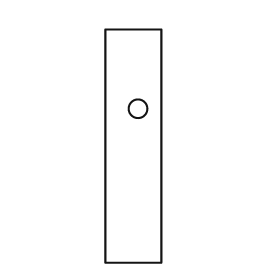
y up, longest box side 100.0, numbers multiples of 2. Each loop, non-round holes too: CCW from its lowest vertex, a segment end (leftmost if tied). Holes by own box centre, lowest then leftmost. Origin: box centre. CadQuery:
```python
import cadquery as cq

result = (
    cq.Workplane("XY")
    .moveTo(-12.0, -50.0)
    .lineTo(12.0, -50.0)
    .lineTo(12.0, 50.0)
    .lineTo(-12.0, 50.0)
    .close()
    .moveTo(2.0, 16.0)
    .circle(4.0)
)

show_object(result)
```